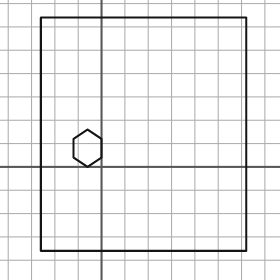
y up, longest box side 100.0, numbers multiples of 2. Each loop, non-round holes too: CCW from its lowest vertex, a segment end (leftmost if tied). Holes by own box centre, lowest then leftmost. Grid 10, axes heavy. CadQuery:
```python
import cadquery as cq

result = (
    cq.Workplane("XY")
    .moveTo(-26.0, -36.0)
    .lineTo(62.0, -36.0)
    .lineTo(62.0, 64.0)
    .lineTo(-26.0, 64.0)
    .close()
    .moveTo(-6.0, 0.0)
    .lineTo(0.0, 4.0)
    .lineTo(0.0, 12.0)
    .lineTo(-6.0, 16.0)
    .lineTo(-12.0, 12.0)
    .lineTo(-12.0, 4.0)
    .close()
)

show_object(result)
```